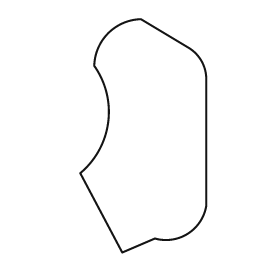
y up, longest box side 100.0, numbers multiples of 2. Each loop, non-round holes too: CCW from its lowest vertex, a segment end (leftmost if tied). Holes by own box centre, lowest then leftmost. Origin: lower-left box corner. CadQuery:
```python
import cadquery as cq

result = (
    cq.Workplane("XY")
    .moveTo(18.0, 0.0)
    .lineTo(32.0, 6.0)
    .threePointArc((46.0, 8.0), (54.0, 20.0))
    .lineTo(54.0, 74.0)
    .threePointArc((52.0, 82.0), (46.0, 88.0))
    .lineTo(26.0, 100.0)
    .threePointArc((12.0, 94.0), (6.0, 80.0))
    .threePointArc((12.0, 56.0), (0.0, 34.0))
    .close()
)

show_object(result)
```